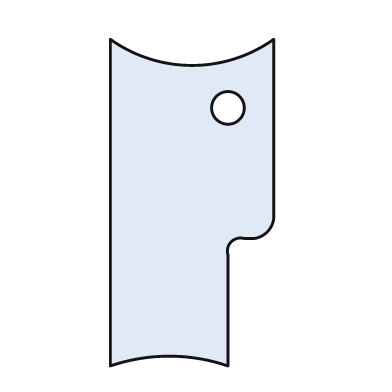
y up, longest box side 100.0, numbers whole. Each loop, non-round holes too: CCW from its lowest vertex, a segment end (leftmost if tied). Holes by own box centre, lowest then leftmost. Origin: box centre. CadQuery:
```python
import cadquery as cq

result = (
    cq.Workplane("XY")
    .moveTo(-25.0, -50.0)
    .threePointArc((-7.0, -47.0), (11.0, -50.0))
    .lineTo(11.0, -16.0)
    .threePointArc((12.0, -12.0), (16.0, -11.0))
    .lineTo(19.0, -11.0)
    .threePointArc((23.0, -9.0), (25.0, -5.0))
    .lineTo(25.0, 50.0)
    .threePointArc((0.0, 42.0), (-25.0, 50.0))
    .close()
    .moveTo(11.0, 29.0)
    .circle(5.0)
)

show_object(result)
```